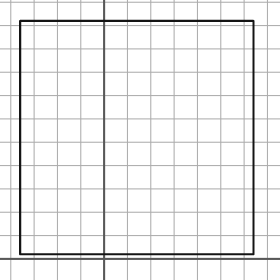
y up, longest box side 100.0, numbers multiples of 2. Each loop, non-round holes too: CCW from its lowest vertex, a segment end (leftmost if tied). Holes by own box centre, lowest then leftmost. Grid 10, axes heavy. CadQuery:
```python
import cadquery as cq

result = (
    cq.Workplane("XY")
    .moveTo(-36.0, 2.0)
    .lineTo(64.0, 2.0)
    .lineTo(64.0, 102.0)
    .lineTo(-36.0, 102.0)
    .close()
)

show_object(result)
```